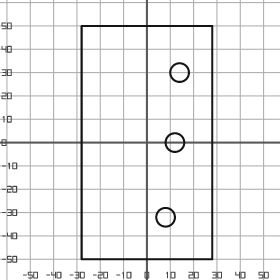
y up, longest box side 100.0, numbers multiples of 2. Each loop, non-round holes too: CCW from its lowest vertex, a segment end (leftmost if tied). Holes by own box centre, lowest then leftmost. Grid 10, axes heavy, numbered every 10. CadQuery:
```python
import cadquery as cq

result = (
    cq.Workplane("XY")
    .moveTo(-28.0, -50.0)
    .lineTo(28.0, -50.0)
    .lineTo(28.0, 50.0)
    .lineTo(-28.0, 50.0)
    .close()
    .moveTo(8.0, -32.0)
    .circle(4.0)
    .moveTo(12.0, 0.0)
    .circle(4.0)
    .moveTo(14.0, 30.0)
    .circle(4.0)
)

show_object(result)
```